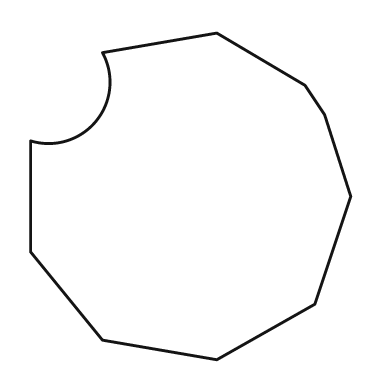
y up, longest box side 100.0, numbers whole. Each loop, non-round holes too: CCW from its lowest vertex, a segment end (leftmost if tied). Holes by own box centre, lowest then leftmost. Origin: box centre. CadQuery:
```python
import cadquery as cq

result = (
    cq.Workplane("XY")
    .moveTo(8.0, -50.0)
    .lineTo(38.0, -33.0)
    .lineTo(49.0, 0.0)
    .lineTo(41.0, 25.0)
    .lineTo(35.0, 34.0)
    .lineTo(8.0, 50.0)
    .lineTo(-27.0, 44.0)
    .threePointArc((-29.0, 23.0), (-49.0, 17.0))
    .lineTo(-49.0, -17.0)
    .lineTo(-27.0, -44.0)
    .close()
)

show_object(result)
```